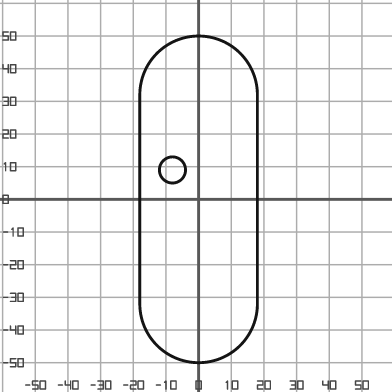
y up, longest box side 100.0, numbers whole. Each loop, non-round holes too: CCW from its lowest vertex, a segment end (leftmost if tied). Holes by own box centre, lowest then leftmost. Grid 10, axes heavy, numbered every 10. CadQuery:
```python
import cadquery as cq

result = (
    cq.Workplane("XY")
    .moveTo(-18.0, -32.0)
    .threePointArc((0.0, -50.0), (18.0, -32.0))
    .lineTo(18.0, 32.0)
    .threePointArc((0.0, 50.0), (-18.0, 32.0))
    .close()
    .moveTo(-8.0, 9.0)
    .circle(4.0)
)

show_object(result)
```